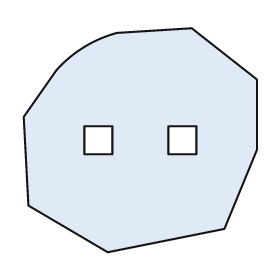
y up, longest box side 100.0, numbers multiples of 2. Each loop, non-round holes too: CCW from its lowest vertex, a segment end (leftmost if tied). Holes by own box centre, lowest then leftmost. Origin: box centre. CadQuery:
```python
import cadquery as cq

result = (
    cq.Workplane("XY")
    .moveTo(-14.0, -48.0)
    .lineTo(36.0, -38.0)
    .lineTo(50.0, -4.0)
    .lineTo(50.0, 26.0)
    .lineTo(22.0, 48.0)
    .lineTo(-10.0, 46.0)
    .threePointArc((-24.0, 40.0), (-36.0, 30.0))
    .lineTo(-50.0, 10.0)
    .lineTo(-48.0, -28.0)
    .close()
    .moveTo(-24.0, -6.0)
    .lineTo(-12.0, -6.0)
    .lineTo(-12.0, 6.0)
    .lineTo(-24.0, 6.0)
    .close()
    .moveTo(12.0, -6.0)
    .lineTo(24.0, -6.0)
    .lineTo(24.0, 6.0)
    .lineTo(12.0, 6.0)
    .close()
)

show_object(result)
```